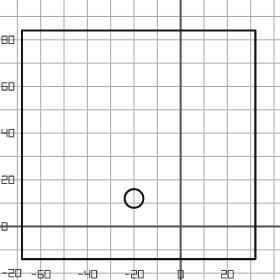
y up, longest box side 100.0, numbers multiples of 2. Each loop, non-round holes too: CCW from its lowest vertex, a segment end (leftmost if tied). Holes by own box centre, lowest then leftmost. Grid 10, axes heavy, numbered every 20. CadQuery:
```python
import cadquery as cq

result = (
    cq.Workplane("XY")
    .moveTo(-68.0, -14.0)
    .lineTo(32.0, -14.0)
    .lineTo(32.0, 84.0)
    .lineTo(-68.0, 84.0)
    .close()
    .moveTo(-20.0, 12.0)
    .circle(4.0)
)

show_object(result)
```